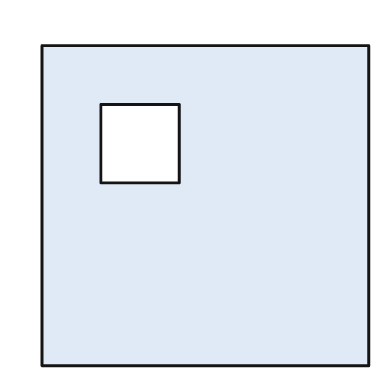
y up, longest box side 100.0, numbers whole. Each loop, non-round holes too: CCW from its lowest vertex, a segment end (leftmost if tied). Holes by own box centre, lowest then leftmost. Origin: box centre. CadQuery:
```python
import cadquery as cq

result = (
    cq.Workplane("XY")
    .moveTo(-50.0, -49.0)
    .lineTo(50.0, -49.0)
    .lineTo(50.0, 49.0)
    .lineTo(-50.0, 49.0)
    .close()
    .moveTo(-32.0, 7.0)
    .lineTo(-8.0, 7.0)
    .lineTo(-8.0, 31.0)
    .lineTo(-32.0, 31.0)
    .close()
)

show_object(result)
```